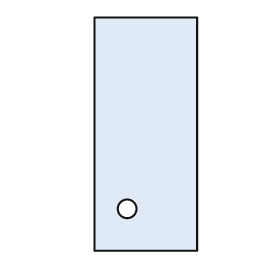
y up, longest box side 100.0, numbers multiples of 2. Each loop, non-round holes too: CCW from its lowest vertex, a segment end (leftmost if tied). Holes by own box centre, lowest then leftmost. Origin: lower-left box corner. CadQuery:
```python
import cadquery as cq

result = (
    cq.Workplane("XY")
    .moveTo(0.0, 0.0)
    .lineTo(44.0, 0.0)
    .lineTo(44.0, 100.0)
    .lineTo(0.0, 100.0)
    .close()
    .moveTo(14.0, 18.0)
    .circle(4.0)
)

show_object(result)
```